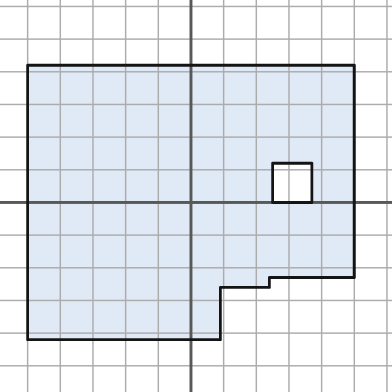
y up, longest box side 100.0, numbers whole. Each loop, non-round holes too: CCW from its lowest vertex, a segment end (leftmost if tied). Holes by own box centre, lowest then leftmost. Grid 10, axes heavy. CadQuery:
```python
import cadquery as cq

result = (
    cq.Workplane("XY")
    .moveTo(-50.0, -42.0)
    .lineTo(9.0, -42.0)
    .lineTo(9.0, -26.0)
    .lineTo(24.0, -26.0)
    .lineTo(24.0, -23.0)
    .lineTo(50.0, -23.0)
    .lineTo(50.0, 42.0)
    .lineTo(-50.0, 42.0)
    .close()
    .moveTo(25.0, 0.0)
    .lineTo(37.0, 0.0)
    .lineTo(37.0, 12.0)
    .lineTo(25.0, 12.0)
    .close()
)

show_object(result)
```